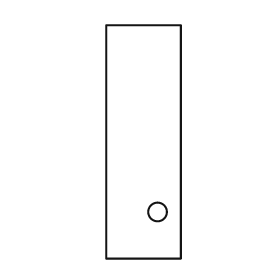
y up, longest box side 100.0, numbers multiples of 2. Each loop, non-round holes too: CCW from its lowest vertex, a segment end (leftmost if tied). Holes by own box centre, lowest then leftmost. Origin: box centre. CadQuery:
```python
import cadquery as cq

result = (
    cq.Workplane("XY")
    .moveTo(-16.0, -50.0)
    .lineTo(16.0, -50.0)
    .lineTo(16.0, 50.0)
    .lineTo(-16.0, 50.0)
    .close()
    .moveTo(6.0, -30.0)
    .circle(4.0)
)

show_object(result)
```